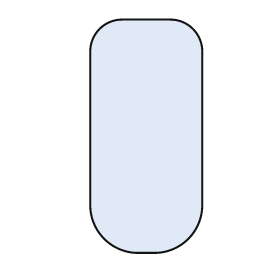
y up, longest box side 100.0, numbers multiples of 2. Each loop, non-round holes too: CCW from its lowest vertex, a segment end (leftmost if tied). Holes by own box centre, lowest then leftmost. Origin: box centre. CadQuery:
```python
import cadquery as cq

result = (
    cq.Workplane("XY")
    .moveTo(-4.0, -50.0)
    .lineTo(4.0, -50.0)
    .threePointArc((18.0, -44.0), (24.0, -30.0))
    .lineTo(24.0, 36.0)
    .threePointArc((20.0, 46.0), (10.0, 50.0))
    .lineTo(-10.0, 50.0)
    .threePointArc((-20.0, 46.0), (-24.0, 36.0))
    .lineTo(-24.0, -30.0)
    .threePointArc((-18.0, -44.0), (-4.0, -50.0))
    .close()
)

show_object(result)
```